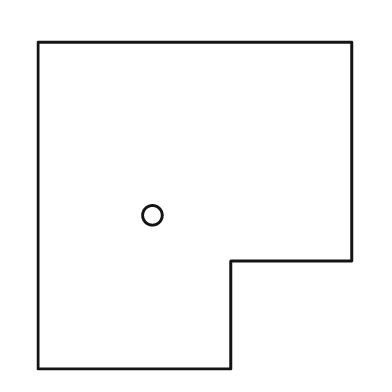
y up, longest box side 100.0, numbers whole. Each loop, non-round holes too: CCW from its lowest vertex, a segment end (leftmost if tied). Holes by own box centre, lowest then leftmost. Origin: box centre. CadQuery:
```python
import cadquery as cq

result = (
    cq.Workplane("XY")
    .moveTo(-48.0, -50.0)
    .lineTo(11.0, -50.0)
    .lineTo(11.0, -17.0)
    .lineTo(48.0, -17.0)
    .lineTo(48.0, 50.0)
    .lineTo(-48.0, 50.0)
    .close()
    .moveTo(-13.0, -3.0)
    .circle(3.0)
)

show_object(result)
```